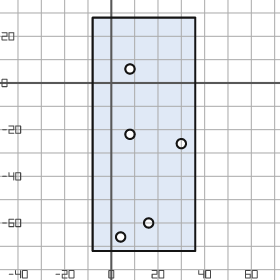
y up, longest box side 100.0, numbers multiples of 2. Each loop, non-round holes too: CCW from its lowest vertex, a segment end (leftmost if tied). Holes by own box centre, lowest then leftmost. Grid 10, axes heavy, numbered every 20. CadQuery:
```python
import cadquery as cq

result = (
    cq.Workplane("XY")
    .moveTo(-8.0, -72.0)
    .lineTo(36.0, -72.0)
    .lineTo(36.0, 28.0)
    .lineTo(-8.0, 28.0)
    .close()
    .moveTo(4.0, -66.0)
    .circle(2.0)
    .moveTo(16.0, -60.0)
    .circle(2.0)
    .moveTo(30.0, -26.0)
    .circle(2.0)
    .moveTo(8.0, -22.0)
    .circle(2.0)
    .moveTo(8.0, 6.0)
    .circle(2.0)
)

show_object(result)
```